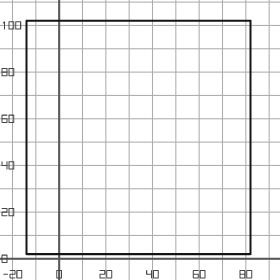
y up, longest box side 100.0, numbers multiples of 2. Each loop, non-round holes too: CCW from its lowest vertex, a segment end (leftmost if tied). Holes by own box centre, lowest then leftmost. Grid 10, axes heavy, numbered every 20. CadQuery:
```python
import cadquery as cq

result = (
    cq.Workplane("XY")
    .moveTo(-14.0, 2.0)
    .lineTo(82.0, 2.0)
    .lineTo(82.0, 102.0)
    .lineTo(-14.0, 102.0)
    .close()
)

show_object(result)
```